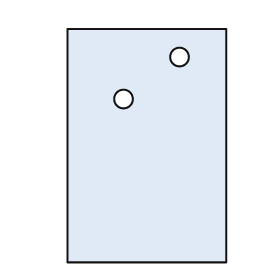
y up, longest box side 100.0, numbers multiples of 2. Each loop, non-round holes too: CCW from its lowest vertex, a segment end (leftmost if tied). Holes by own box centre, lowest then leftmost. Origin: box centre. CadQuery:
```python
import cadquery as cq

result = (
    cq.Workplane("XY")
    .moveTo(-34.0, -50.0)
    .lineTo(34.0, -50.0)
    .lineTo(34.0, 50.0)
    .lineTo(-34.0, 50.0)
    .close()
    .moveTo(-10.0, 20.0)
    .circle(4.0)
    .moveTo(14.0, 38.0)
    .circle(4.0)
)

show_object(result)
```